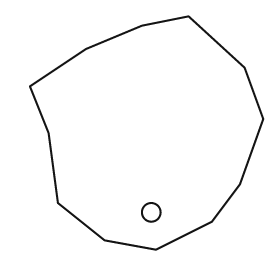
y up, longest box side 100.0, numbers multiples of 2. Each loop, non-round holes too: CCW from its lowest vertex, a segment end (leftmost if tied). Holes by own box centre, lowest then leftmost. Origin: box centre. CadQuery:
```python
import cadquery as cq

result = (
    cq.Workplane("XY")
    .moveTo(4.0, -50.0)
    .lineTo(28.0, -38.0)
    .lineTo(40.0, -22.0)
    .lineTo(50.0, 6.0)
    .lineTo(42.0, 28.0)
    .lineTo(18.0, 50.0)
    .lineTo(-2.0, 46.0)
    .lineTo(-26.0, 36.0)
    .lineTo(-50.0, 20.0)
    .lineTo(-42.0, 0.0)
    .lineTo(-38.0, -30.0)
    .lineTo(-18.0, -46.0)
    .close()
    .moveTo(2.0, -34.0)
    .circle(4.0)
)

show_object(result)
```